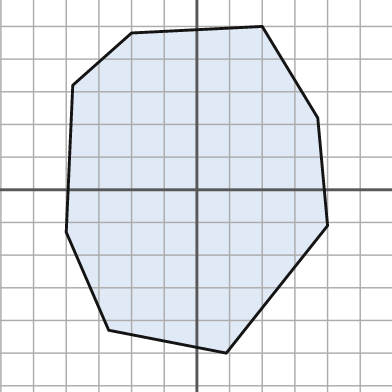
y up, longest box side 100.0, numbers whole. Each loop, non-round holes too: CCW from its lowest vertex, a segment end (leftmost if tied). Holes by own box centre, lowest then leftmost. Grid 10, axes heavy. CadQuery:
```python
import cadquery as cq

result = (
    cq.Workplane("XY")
    .moveTo(9.0, -50.0)
    .lineTo(40.0, -11.0)
    .lineTo(37.0, 22.0)
    .lineTo(20.0, 50.0)
    .lineTo(-20.0, 48.0)
    .lineTo(-38.0, 32.0)
    .lineTo(-40.0, -13.0)
    .lineTo(-27.0, -43.0)
    .close()
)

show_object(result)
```